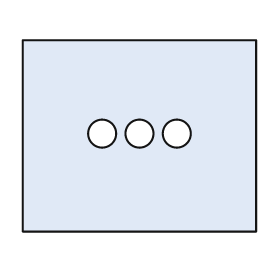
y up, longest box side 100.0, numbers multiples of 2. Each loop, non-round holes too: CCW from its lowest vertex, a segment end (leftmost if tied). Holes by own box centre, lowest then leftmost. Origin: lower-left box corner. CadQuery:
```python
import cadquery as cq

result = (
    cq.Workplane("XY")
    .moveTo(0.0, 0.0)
    .lineTo(100.0, 0.0)
    .lineTo(100.0, 82.0)
    .lineTo(0.0, 82.0)
    .close()
    .moveTo(34.0, 42.0)
    .circle(6.0)
    .moveTo(50.0, 42.0)
    .circle(6.0)
    .moveTo(66.0, 42.0)
    .circle(6.0)
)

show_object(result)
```